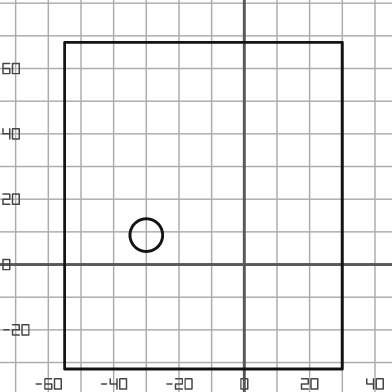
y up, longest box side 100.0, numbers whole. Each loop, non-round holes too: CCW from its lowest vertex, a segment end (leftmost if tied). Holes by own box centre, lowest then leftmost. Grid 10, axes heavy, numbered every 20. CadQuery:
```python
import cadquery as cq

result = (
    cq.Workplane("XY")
    .moveTo(-55.0, -32.0)
    .lineTo(30.0, -32.0)
    .lineTo(30.0, 68.0)
    .lineTo(-55.0, 68.0)
    .close()
    .moveTo(-30.0, 9.0)
    .circle(5.0)
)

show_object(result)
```